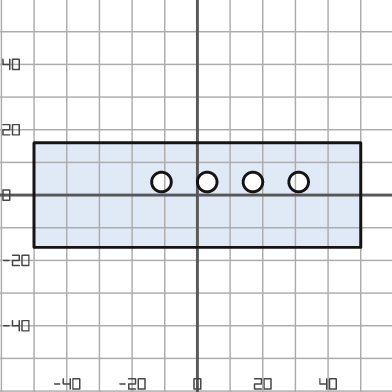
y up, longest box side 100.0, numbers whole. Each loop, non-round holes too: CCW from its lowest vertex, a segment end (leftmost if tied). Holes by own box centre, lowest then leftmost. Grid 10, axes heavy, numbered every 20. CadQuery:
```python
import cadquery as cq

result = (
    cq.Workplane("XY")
    .moveTo(-50.0, -16.0)
    .lineTo(50.0, -16.0)
    .lineTo(50.0, 16.0)
    .lineTo(-50.0, 16.0)
    .close()
    .moveTo(-11.0, 4.0)
    .circle(3.0)
    .moveTo(3.0, 4.0)
    .circle(3.0)
    .moveTo(17.0, 4.0)
    .circle(3.0)
    .moveTo(31.0, 4.0)
    .circle(3.0)
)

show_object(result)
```